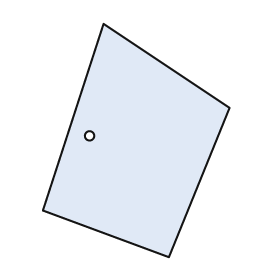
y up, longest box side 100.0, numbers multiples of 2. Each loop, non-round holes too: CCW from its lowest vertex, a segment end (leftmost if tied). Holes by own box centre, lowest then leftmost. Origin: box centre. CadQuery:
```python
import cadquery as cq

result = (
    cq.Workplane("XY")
    .moveTo(14.0, -50.0)
    .lineTo(40.0, 14.0)
    .lineTo(-14.0, 50.0)
    .lineTo(-40.0, -30.0)
    .close()
    .moveTo(-20.0, 2.0)
    .circle(2.0)
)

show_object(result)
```